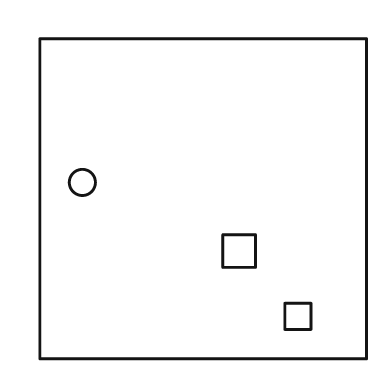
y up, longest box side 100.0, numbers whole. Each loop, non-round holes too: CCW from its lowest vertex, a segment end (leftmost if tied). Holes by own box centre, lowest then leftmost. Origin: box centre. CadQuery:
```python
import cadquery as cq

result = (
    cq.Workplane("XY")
    .moveTo(-50.0, -49.0)
    .lineTo(50.0, -49.0)
    .lineTo(50.0, 49.0)
    .lineTo(-50.0, 49.0)
    .close()
    .moveTo(25.0, -40.0)
    .lineTo(33.0, -40.0)
    .lineTo(33.0, -32.0)
    .lineTo(25.0, -32.0)
    .close()
    .moveTo(6.0, -21.0)
    .lineTo(16.0, -21.0)
    .lineTo(16.0, -11.0)
    .lineTo(6.0, -11.0)
    .close()
    .moveTo(-37.0, 5.0)
    .circle(4.0)
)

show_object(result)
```